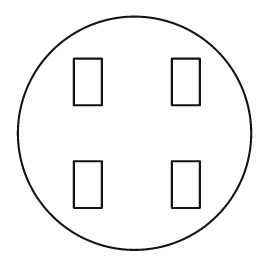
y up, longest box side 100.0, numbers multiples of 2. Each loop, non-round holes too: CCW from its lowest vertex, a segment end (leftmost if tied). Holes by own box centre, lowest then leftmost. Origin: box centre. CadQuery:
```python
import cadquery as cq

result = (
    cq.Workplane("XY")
    .moveTo(0.0, 0.0)
    .circle(50.0)
    .moveTo(-26.0, -32.0)
    .lineTo(-14.0, -32.0)
    .lineTo(-14.0, -12.0)
    .lineTo(-26.0, -12.0)
    .close()
    .moveTo(16.0, -32.0)
    .lineTo(28.0, -32.0)
    .lineTo(28.0, -12.0)
    .lineTo(16.0, -12.0)
    .close()
    .moveTo(-26.0, 12.0)
    .lineTo(-14.0, 12.0)
    .lineTo(-14.0, 32.0)
    .lineTo(-26.0, 32.0)
    .close()
    .moveTo(16.0, 12.0)
    .lineTo(28.0, 12.0)
    .lineTo(28.0, 32.0)
    .lineTo(16.0, 32.0)
    .close()
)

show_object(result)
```